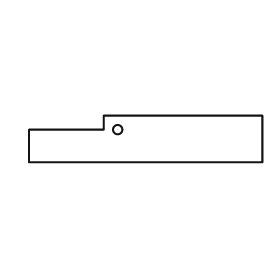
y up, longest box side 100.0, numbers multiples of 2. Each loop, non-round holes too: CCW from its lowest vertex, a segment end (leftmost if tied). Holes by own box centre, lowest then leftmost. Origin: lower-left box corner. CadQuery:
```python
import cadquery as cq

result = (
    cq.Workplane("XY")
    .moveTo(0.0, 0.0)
    .lineTo(100.0, 0.0)
    .lineTo(100.0, 20.0)
    .lineTo(32.0, 20.0)
    .lineTo(32.0, 14.0)
    .lineTo(0.0, 14.0)
    .close()
    .moveTo(38.0, 14.0)
    .circle(2.0)
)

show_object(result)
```